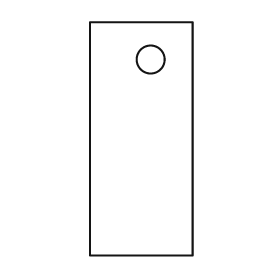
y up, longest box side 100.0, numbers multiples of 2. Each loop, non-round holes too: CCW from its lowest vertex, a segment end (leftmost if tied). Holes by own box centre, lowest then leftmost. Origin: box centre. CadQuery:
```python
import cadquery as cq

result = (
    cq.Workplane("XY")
    .moveTo(-22.0, -50.0)
    .lineTo(22.0, -50.0)
    .lineTo(22.0, 50.0)
    .lineTo(-22.0, 50.0)
    .close()
    .moveTo(4.0, 34.0)
    .circle(6.0)
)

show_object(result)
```